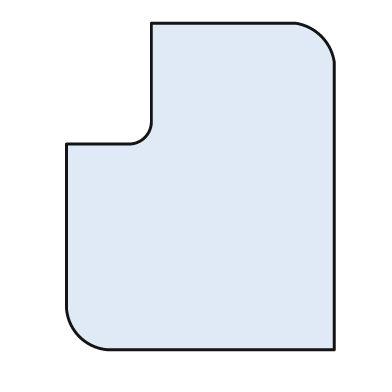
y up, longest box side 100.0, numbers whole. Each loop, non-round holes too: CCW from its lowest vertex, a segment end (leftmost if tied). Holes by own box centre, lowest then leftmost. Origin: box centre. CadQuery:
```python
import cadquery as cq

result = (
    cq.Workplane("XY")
    .moveTo(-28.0, -50.0)
    .lineTo(41.0, -50.0)
    .lineTo(41.0, 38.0)
    .threePointArc((37.0, 46.0), (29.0, 50.0))
    .lineTo(-15.0, 50.0)
    .lineTo(-15.0, 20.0)
    .threePointArc((-17.0, 15.0), (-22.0, 13.0))
    .lineTo(-41.0, 13.0)
    .lineTo(-41.0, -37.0)
    .threePointArc((-37.0, -46.0), (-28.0, -50.0))
    .close()
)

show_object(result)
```